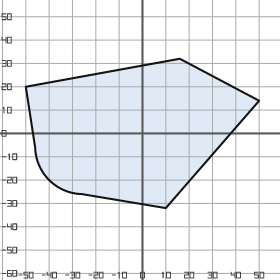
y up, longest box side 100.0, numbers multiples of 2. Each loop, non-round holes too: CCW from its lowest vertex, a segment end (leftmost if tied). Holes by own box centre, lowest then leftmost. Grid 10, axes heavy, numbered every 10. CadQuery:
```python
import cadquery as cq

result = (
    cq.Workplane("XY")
    .moveTo(10.0, -32.0)
    .lineTo(50.0, 14.0)
    .lineTo(16.0, 32.0)
    .lineTo(-50.0, 20.0)
    .lineTo(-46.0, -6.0)
    .threePointArc((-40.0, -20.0), (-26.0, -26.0))
    .close()
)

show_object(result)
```